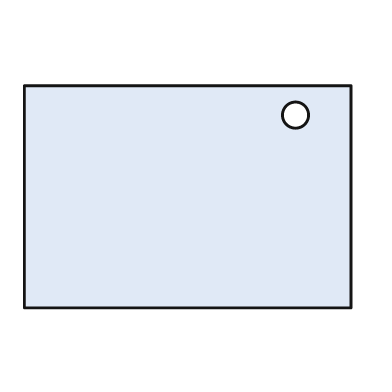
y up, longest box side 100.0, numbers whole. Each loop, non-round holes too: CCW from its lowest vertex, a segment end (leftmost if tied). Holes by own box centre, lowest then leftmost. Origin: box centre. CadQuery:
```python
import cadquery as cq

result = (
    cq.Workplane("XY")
    .moveTo(-50.0, -34.0)
    .lineTo(50.0, -34.0)
    .lineTo(50.0, 34.0)
    .lineTo(-50.0, 34.0)
    .close()
    .moveTo(33.0, 25.0)
    .circle(4.0)
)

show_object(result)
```